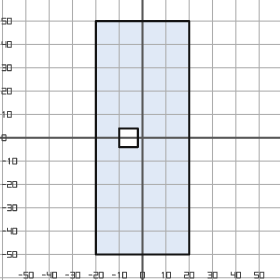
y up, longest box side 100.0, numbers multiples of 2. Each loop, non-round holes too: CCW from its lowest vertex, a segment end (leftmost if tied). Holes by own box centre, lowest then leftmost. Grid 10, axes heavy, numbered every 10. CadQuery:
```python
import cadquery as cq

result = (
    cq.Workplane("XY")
    .moveTo(-20.0, -50.0)
    .lineTo(20.0, -50.0)
    .lineTo(20.0, 50.0)
    .lineTo(-20.0, 50.0)
    .close()
    .moveTo(-10.0, -4.0)
    .lineTo(-2.0, -4.0)
    .lineTo(-2.0, 4.0)
    .lineTo(-10.0, 4.0)
    .close()
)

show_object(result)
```